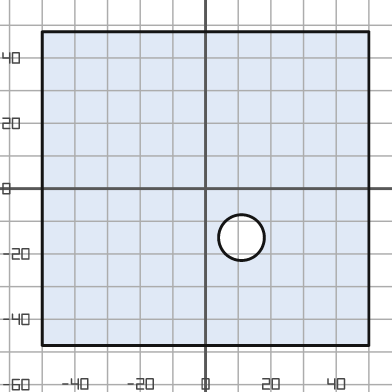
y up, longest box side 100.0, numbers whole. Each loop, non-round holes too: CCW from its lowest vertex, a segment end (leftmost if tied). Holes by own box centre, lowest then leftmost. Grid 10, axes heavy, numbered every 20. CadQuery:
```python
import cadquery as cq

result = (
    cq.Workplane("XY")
    .moveTo(-50.0, -48.0)
    .lineTo(50.0, -48.0)
    .lineTo(50.0, 48.0)
    .lineTo(-50.0, 48.0)
    .close()
    .moveTo(11.0, -15.0)
    .circle(7.0)
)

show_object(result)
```